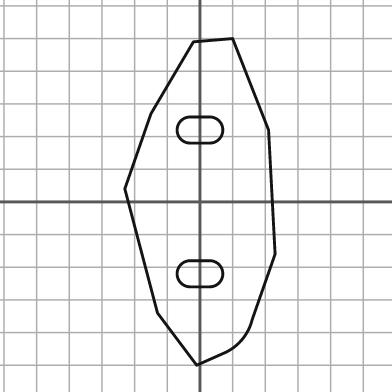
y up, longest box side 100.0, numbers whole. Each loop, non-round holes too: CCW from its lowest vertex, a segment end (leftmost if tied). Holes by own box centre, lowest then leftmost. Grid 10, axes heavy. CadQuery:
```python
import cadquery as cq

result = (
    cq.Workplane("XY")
    .moveTo(-1.0, -50.0)
    .lineTo(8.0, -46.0)
    .threePointArc((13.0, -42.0), (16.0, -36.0))
    .lineTo(23.0, -16.0)
    .lineTo(21.0, 22.0)
    .lineTo(10.0, 50.0)
    .lineTo(-2.0, 49.0)
    .lineTo(-15.0, 27.0)
    .lineTo(-23.0, 4.0)
    .lineTo(-13.0, -34.0)
    .close()
    .moveTo(-3.0, -26.0)
    .lineTo(3.0, -26.0)
    .threePointArc((7.0, -22.0), (3.0, -18.0))
    .lineTo(-3.0, -18.0)
    .threePointArc((-7.0, -22.0), (-3.0, -26.0))
    .close()
    .moveTo(-3.0, 18.0)
    .lineTo(3.0, 18.0)
    .threePointArc((7.0, 22.0), (3.0, 26.0))
    .lineTo(-3.0, 26.0)
    .threePointArc((-7.0, 22.0), (-3.0, 18.0))
    .close()
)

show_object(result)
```